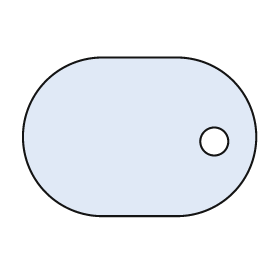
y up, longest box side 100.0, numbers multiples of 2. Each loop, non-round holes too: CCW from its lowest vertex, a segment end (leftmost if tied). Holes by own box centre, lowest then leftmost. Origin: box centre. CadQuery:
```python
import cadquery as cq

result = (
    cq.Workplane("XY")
    .moveTo(-16.0, -34.0)
    .lineTo(16.0, -34.0)
    .threePointArc((50.0, 0.0), (16.0, 34.0))
    .lineTo(-16.0, 34.0)
    .threePointArc((-50.0, 0.0), (-16.0, -34.0))
    .close()
    .moveTo(32.0, -2.0)
    .circle(6.0)
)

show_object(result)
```